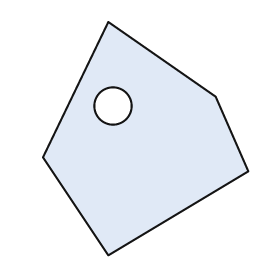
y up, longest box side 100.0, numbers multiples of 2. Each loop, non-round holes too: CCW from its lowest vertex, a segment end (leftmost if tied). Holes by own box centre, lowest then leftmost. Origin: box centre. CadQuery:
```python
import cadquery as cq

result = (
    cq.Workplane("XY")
    .moveTo(-16.0, -50.0)
    .lineTo(44.0, -14.0)
    .lineTo(30.0, 18.0)
    .lineTo(-16.0, 50.0)
    .lineTo(-44.0, -8.0)
    .close()
    .moveTo(-14.0, 14.0)
    .circle(8.0)
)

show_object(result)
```